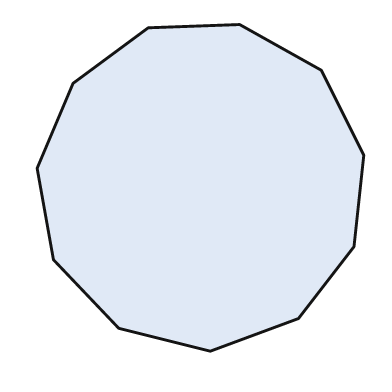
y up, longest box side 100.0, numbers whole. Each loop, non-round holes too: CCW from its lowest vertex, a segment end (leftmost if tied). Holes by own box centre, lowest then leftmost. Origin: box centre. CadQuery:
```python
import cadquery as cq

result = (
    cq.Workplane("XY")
    .moveTo(3.0, -50.0)
    .lineTo(30.0, -40.0)
    .lineTo(47.0, -18.0)
    .lineTo(50.0, 10.0)
    .lineTo(37.0, 36.0)
    .lineTo(12.0, 50.0)
    .lineTo(-16.0, 49.0)
    .lineTo(-39.0, 32.0)
    .lineTo(-50.0, 6.0)
    .lineTo(-45.0, -22.0)
    .lineTo(-25.0, -43.0)
    .close()
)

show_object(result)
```